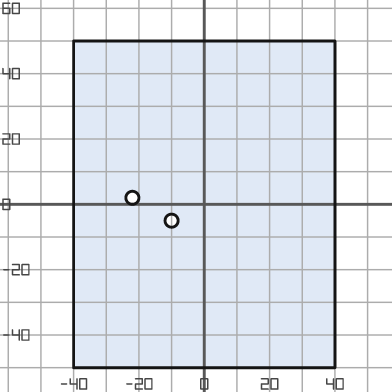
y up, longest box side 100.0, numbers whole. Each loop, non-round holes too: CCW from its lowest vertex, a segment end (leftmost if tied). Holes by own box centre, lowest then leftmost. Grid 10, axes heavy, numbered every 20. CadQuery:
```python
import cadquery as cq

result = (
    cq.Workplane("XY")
    .moveTo(-40.0, -50.0)
    .lineTo(40.0, -50.0)
    .lineTo(40.0, 50.0)
    .lineTo(-40.0, 50.0)
    .close()
    .moveTo(-10.0, -5.0)
    .circle(2.0)
    .moveTo(-22.0, 2.0)
    .circle(2.0)
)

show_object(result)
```